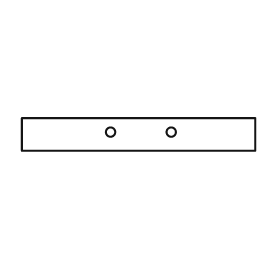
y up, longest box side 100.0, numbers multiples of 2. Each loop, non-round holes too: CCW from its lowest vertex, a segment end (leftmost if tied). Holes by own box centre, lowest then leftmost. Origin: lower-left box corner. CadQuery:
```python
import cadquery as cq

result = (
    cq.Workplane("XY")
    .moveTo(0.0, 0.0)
    .lineTo(100.0, 0.0)
    .lineTo(100.0, 14.0)
    .lineTo(0.0, 14.0)
    .close()
    .moveTo(38.0, 8.0)
    .circle(2.0)
    .moveTo(64.0, 8.0)
    .circle(2.0)
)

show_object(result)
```